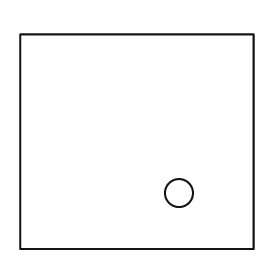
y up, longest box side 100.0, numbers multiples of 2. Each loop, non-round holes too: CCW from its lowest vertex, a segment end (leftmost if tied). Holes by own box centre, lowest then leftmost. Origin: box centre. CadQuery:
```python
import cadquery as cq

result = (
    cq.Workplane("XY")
    .moveTo(-50.0, -46.0)
    .lineTo(50.0, -46.0)
    .lineTo(50.0, 46.0)
    .lineTo(-50.0, 46.0)
    .close()
    .moveTo(18.0, -22.0)
    .circle(6.0)
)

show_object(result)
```